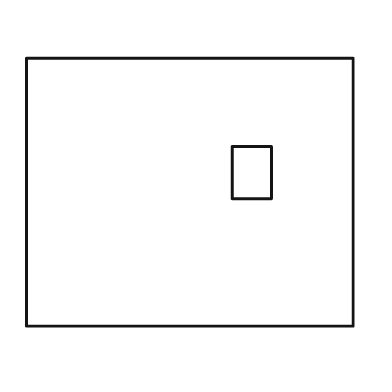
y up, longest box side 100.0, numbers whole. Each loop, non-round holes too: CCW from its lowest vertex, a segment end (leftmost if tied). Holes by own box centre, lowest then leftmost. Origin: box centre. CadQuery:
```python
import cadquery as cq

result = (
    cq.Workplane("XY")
    .moveTo(-50.0, -41.0)
    .lineTo(50.0, -41.0)
    .lineTo(50.0, 41.0)
    .lineTo(-50.0, 41.0)
    .close()
    .moveTo(13.0, -2.0)
    .lineTo(25.0, -2.0)
    .lineTo(25.0, 14.0)
    .lineTo(13.0, 14.0)
    .close()
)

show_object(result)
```